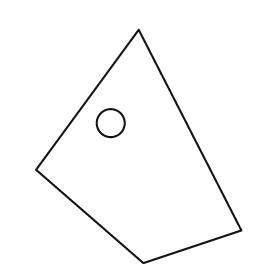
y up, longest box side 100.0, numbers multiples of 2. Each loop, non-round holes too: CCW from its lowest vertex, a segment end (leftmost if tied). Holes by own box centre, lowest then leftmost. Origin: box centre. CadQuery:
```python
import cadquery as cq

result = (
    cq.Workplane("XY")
    .moveTo(2.0, -50.0)
    .lineTo(44.0, -36.0)
    .lineTo(0.0, 50.0)
    .lineTo(-44.0, -10.0)
    .close()
    .moveTo(-12.0, 10.0)
    .circle(6.0)
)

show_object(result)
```